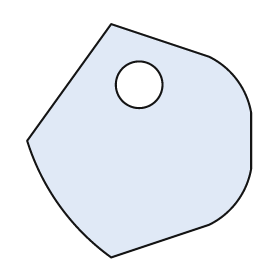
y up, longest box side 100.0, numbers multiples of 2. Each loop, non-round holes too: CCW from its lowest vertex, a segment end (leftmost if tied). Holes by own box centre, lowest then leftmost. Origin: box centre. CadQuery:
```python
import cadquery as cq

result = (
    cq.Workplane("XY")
    .moveTo(-12.0, -50.0)
    .lineTo(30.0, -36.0)
    .threePointArc((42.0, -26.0), (48.0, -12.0))
    .lineTo(48.0, 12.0)
    .threePointArc((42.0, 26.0), (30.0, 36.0))
    .lineTo(-12.0, 50.0)
    .lineTo(-48.0, 0.0)
    .threePointArc((-34.0, -28.0), (-12.0, -50.0))
    .close()
    .moveTo(0.0, 24.0)
    .circle(10.0)
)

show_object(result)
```